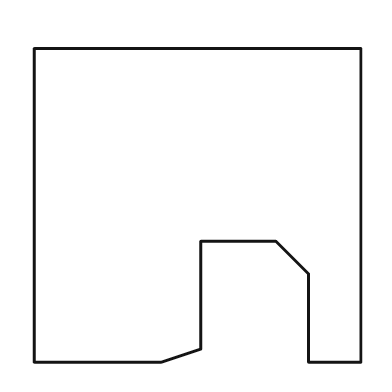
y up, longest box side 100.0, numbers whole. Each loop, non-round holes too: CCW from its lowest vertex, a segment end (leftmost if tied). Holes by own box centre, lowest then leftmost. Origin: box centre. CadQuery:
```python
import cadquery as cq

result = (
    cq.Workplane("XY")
    .moveTo(-50.0, -48.0)
    .lineTo(-11.0, -48.0)
    .lineTo(1.0, -44.0)
    .lineTo(1.0, -11.0)
    .lineTo(24.0, -11.0)
    .lineTo(34.0, -21.0)
    .lineTo(34.0, -48.0)
    .lineTo(50.0, -48.0)
    .lineTo(50.0, 48.0)
    .lineTo(-50.0, 48.0)
    .close()
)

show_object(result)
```